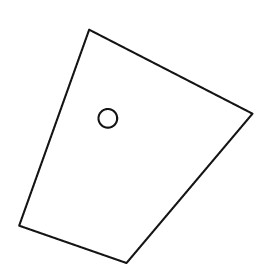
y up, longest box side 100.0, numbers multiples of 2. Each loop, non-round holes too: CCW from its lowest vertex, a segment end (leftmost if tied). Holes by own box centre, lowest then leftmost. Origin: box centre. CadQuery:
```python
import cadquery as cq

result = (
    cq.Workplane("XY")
    .moveTo(-4.0, -50.0)
    .lineTo(50.0, 14.0)
    .lineTo(-20.0, 50.0)
    .lineTo(-50.0, -34.0)
    .close()
    .moveTo(-12.0, 12.0)
    .circle(4.0)
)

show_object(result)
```